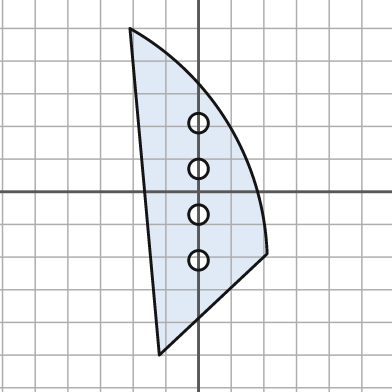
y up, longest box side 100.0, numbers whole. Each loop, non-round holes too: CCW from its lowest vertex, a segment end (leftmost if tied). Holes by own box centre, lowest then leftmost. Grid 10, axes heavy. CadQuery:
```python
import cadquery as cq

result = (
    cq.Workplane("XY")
    .moveTo(-12.0, -50.0)
    .lineTo(21.0, -19.0)
    .threePointArc((9.0, 21.0), (-21.0, 50.0))
    .close()
    .moveTo(0.0, -21.0)
    .circle(3.0)
    .moveTo(0.0, -7.0)
    .circle(3.0)
    .moveTo(0.0, 7.0)
    .circle(3.0)
    .moveTo(0.0, 21.0)
    .circle(3.0)
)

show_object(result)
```